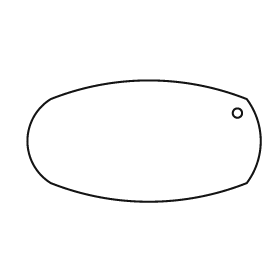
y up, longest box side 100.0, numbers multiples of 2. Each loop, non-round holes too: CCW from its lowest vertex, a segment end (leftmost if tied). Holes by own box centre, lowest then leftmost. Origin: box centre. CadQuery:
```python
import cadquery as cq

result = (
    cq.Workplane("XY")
    .moveTo(-40.0, -18.0)
    .threePointArc((2.0, -26.0), (44.0, -18.0))
    .threePointArc((50.0, 0.0), (44.0, 18.0))
    .threePointArc((2.0, 26.0), (-40.0, 18.0))
    .threePointArc((-50.0, 0.0), (-40.0, -18.0))
    .close()
    .moveTo(40.0, 12.0)
    .circle(2.0)
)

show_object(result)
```